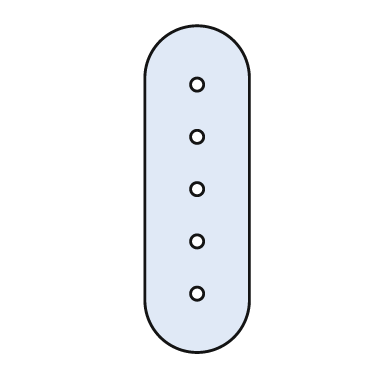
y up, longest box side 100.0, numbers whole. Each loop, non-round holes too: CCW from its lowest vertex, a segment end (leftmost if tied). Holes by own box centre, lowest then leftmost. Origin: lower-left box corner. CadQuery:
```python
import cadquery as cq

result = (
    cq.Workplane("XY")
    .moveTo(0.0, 16.0)
    .threePointArc((16.0, 0.0), (32.0, 16.0))
    .lineTo(32.0, 84.0)
    .threePointArc((16.0, 100.0), (0.0, 84.0))
    .close()
    .moveTo(16.0, 18.0)
    .circle(2.0)
    .moveTo(16.0, 34.0)
    .circle(2.0)
    .moveTo(16.0, 50.0)
    .circle(2.0)
    .moveTo(16.0, 66.0)
    .circle(2.0)
    .moveTo(16.0, 82.0)
    .circle(2.0)
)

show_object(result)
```